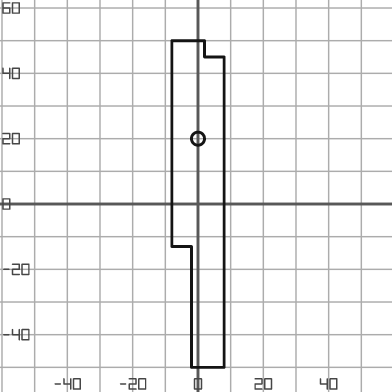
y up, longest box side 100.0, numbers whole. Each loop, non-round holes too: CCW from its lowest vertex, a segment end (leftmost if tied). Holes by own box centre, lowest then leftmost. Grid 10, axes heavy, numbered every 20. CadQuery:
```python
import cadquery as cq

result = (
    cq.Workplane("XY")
    .moveTo(-2.0, -50.0)
    .lineTo(8.0, -50.0)
    .lineTo(8.0, 45.0)
    .lineTo(2.0, 45.0)
    .lineTo(2.0, 50.0)
    .lineTo(-8.0, 50.0)
    .lineTo(-8.0, -13.0)
    .lineTo(-2.0, -13.0)
    .close()
    .moveTo(0.0, 20.0)
    .circle(2.0)
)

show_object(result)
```